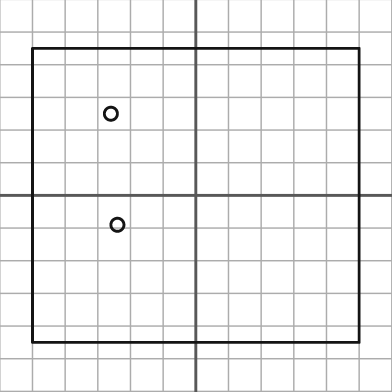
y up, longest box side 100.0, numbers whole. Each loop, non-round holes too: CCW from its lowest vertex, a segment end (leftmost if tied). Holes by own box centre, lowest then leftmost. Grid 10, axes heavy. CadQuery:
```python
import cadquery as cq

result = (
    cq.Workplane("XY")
    .moveTo(-50.0, -45.0)
    .lineTo(50.0, -45.0)
    .lineTo(50.0, 45.0)
    .lineTo(-50.0, 45.0)
    .close()
    .moveTo(-24.0, -9.0)
    .circle(2.0)
    .moveTo(-26.0, 25.0)
    .circle(2.0)
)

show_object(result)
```